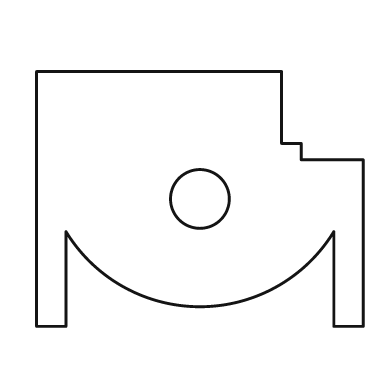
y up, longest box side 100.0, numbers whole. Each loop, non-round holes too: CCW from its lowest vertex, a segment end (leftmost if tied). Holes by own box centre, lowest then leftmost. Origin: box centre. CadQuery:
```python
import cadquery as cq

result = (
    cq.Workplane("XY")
    .moveTo(-50.0, -39.0)
    .lineTo(-41.0, -39.0)
    .lineTo(-41.0, -10.0)
    .threePointArc((0.0, -33.0), (41.0, -10.0))
    .lineTo(41.0, -39.0)
    .lineTo(50.0, -39.0)
    .lineTo(50.0, 12.0)
    .lineTo(31.0, 12.0)
    .lineTo(31.0, 17.0)
    .lineTo(25.0, 17.0)
    .lineTo(25.0, 39.0)
    .lineTo(-50.0, 39.0)
    .close()
    .moveTo(0.0, 0.0)
    .circle(9.0)
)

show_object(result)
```